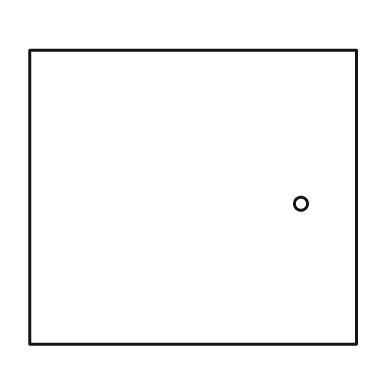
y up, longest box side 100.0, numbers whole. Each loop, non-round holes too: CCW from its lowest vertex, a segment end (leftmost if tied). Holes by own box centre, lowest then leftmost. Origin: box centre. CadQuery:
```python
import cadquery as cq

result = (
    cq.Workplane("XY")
    .moveTo(-50.0, -45.0)
    .lineTo(50.0, -45.0)
    .lineTo(50.0, 45.0)
    .lineTo(-50.0, 45.0)
    .close()
    .moveTo(33.0, -2.0)
    .circle(2.0)
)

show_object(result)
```